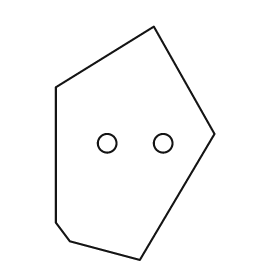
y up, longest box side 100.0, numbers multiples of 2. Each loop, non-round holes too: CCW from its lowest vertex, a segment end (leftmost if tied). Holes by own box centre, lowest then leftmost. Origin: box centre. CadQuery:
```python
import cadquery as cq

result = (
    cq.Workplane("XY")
    .moveTo(2.0, -50.0)
    .lineTo(34.0, 4.0)
    .lineTo(8.0, 50.0)
    .lineTo(-34.0, 24.0)
    .lineTo(-34.0, -34.0)
    .lineTo(-28.0, -42.0)
    .close()
    .moveTo(-12.0, 0.0)
    .circle(4.0)
    .moveTo(12.0, 0.0)
    .circle(4.0)
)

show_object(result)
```